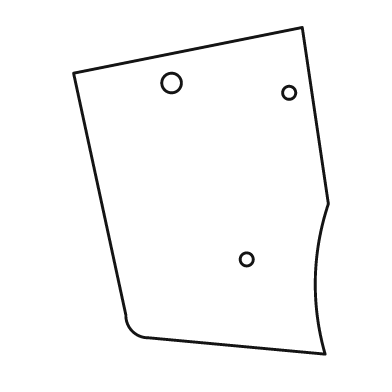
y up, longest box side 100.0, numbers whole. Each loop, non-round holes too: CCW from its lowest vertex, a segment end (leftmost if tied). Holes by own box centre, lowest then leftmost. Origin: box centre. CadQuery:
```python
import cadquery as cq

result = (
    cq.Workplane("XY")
    .moveTo(38.0, -50.0)
    .threePointArc((35.0, -27.0), (39.0, -4.0))
    .lineTo(31.0, 50.0)
    .lineTo(-39.0, 36.0)
    .lineTo(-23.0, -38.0)
    .threePointArc((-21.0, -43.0), (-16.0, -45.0))
    .close()
    .moveTo(14.0, -21.0)
    .circle(2.0)
    .moveTo(27.0, 30.0)
    .circle(2.0)
    .moveTo(-9.0, 33.0)
    .circle(3.0)
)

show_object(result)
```